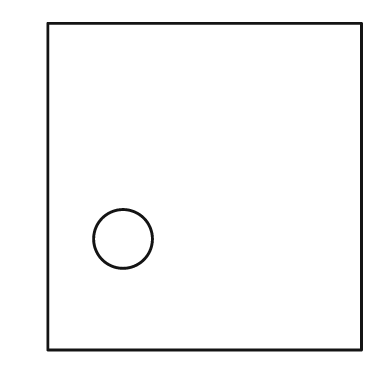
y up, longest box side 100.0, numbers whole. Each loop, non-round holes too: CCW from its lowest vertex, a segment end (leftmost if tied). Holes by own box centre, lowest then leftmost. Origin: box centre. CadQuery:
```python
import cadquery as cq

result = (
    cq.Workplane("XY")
    .moveTo(-48.0, -50.0)
    .lineTo(48.0, -50.0)
    .lineTo(48.0, 50.0)
    .lineTo(-48.0, 50.0)
    .close()
    .moveTo(-25.0, -16.0)
    .circle(9.0)
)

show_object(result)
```